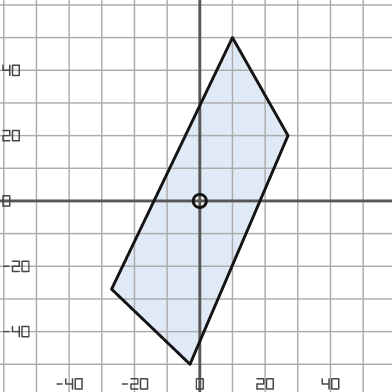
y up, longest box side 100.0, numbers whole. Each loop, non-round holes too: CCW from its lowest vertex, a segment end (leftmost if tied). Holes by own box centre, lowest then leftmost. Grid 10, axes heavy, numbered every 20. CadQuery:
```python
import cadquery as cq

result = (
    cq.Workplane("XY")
    .moveTo(-3.0, -50.0)
    .lineTo(27.0, 20.0)
    .lineTo(10.0, 50.0)
    .lineTo(-27.0, -27.0)
    .close()
    .moveTo(0.0, 0.0)
    .circle(2.0)
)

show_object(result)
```